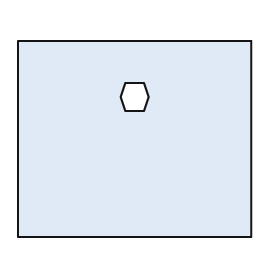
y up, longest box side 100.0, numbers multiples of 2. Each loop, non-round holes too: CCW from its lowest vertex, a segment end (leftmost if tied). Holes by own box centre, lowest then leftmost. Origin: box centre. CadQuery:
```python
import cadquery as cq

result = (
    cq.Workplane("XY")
    .moveTo(-50.0, -42.0)
    .lineTo(50.0, -42.0)
    .lineTo(50.0, 42.0)
    .lineTo(-50.0, 42.0)
    .close()
    .moveTo(-4.0, 12.0)
    .lineTo(4.0, 12.0)
    .lineTo(6.0, 18.0)
    .lineTo(4.0, 24.0)
    .lineTo(-4.0, 24.0)
    .lineTo(-6.0, 18.0)
    .close()
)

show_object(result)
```